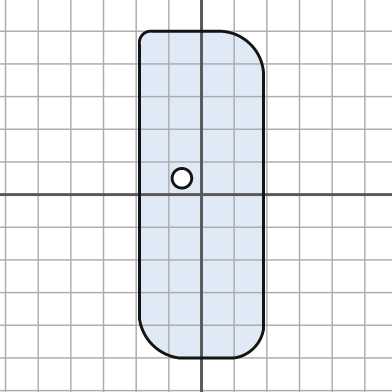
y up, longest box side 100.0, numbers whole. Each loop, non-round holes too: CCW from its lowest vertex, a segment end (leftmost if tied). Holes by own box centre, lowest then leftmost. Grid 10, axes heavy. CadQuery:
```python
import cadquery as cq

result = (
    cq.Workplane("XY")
    .moveTo(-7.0, -50.0)
    .lineTo(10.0, -50.0)
    .threePointArc((16.0, -47.0), (19.0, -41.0))
    .lineTo(19.0, 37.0)
    .threePointArc((15.0, 46.0), (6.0, 50.0))
    .lineTo(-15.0, 50.0)
    .threePointArc((-18.0, 49.0), (-19.0, 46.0))
    .lineTo(-19.0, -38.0)
    .threePointArc((-15.0, -46.0), (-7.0, -50.0))
    .close()
    .moveTo(-6.0, 5.0)
    .circle(3.0)
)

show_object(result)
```